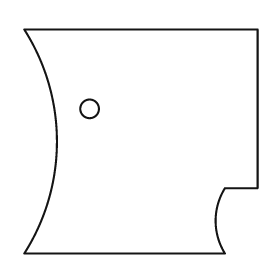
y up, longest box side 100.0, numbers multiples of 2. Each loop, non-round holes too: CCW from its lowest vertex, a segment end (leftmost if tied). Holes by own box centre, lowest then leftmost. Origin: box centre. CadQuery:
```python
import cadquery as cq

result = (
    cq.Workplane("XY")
    .moveTo(-50.0, -48.0)
    .lineTo(36.0, -48.0)
    .threePointArc((32.0, -34.0), (36.0, -20.0))
    .lineTo(50.0, -20.0)
    .lineTo(50.0, 48.0)
    .lineTo(-50.0, 48.0)
    .threePointArc((-36.0, 0.0), (-50.0, -48.0))
    .close()
    .moveTo(-22.0, 14.0)
    .circle(4.0)
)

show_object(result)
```